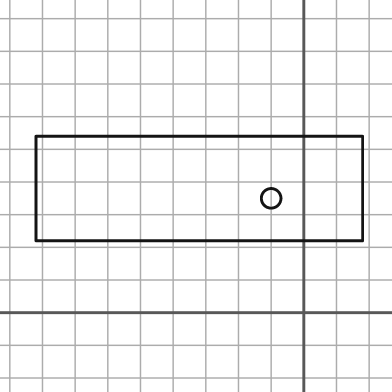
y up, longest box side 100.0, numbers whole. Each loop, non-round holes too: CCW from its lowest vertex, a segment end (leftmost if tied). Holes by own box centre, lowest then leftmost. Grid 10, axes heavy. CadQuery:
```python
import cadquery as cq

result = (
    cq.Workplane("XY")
    .moveTo(-82.0, 22.0)
    .lineTo(18.0, 22.0)
    .lineTo(18.0, 54.0)
    .lineTo(-82.0, 54.0)
    .close()
    .moveTo(-10.0, 35.0)
    .circle(3.0)
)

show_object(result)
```